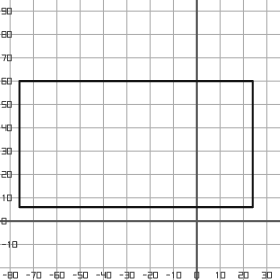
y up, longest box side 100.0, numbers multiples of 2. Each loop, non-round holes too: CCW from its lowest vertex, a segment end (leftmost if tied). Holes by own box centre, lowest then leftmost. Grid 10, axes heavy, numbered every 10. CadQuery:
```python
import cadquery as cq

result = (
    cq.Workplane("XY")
    .moveTo(-76.0, 6.0)
    .lineTo(24.0, 6.0)
    .lineTo(24.0, 60.0)
    .lineTo(-76.0, 60.0)
    .close()
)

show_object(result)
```